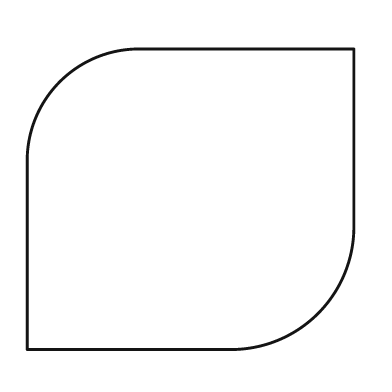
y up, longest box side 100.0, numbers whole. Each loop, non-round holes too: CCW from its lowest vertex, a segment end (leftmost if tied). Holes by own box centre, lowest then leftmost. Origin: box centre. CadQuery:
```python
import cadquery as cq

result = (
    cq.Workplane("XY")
    .moveTo(-50.0, -46.0)
    .lineTo(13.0, -46.0)
    .threePointArc((39.0, -35.0), (50.0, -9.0))
    .lineTo(50.0, 46.0)
    .lineTo(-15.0, 46.0)
    .threePointArc((-40.0, 36.0), (-50.0, 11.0))
    .close()
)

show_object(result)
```